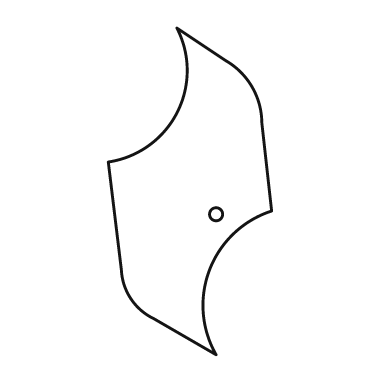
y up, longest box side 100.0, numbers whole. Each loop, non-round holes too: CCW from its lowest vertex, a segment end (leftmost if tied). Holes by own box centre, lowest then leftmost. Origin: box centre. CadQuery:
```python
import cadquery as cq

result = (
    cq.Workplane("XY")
    .moveTo(8.0, -50.0)
    .threePointArc((6.0, -24.0), (25.0, -6.0))
    .lineTo(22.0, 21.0)
    .threePointArc((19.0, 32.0), (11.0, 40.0))
    .lineTo(-4.0, 50.0)
    .threePointArc((-4.0, 24.0), (-25.0, 9.0))
    .lineTo(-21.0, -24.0)
    .threePointArc((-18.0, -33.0), (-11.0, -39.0))
    .close()
    .moveTo(8.0, -7.0)
    .circle(2.0)
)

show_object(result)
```